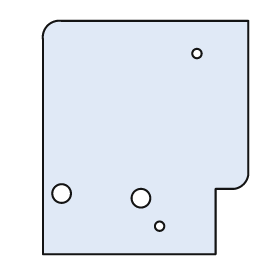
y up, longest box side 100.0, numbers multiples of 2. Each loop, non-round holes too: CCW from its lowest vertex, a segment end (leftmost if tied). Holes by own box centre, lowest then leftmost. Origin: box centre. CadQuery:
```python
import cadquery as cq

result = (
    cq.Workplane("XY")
    .moveTo(-44.0, -50.0)
    .lineTo(30.0, -50.0)
    .lineTo(30.0, -22.0)
    .lineTo(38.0, -22.0)
    .threePointArc((42.0, -20.0), (44.0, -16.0))
    .lineTo(44.0, 50.0)
    .lineTo(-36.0, 50.0)
    .threePointArc((-42.0, 48.0), (-44.0, 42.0))
    .close()
    .moveTo(6.0, -38.0)
    .circle(2.0)
    .moveTo(-2.0, -26.0)
    .circle(4.0)
    .moveTo(-36.0, -24.0)
    .circle(4.0)
    .moveTo(22.0, 36.0)
    .circle(2.0)
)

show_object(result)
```